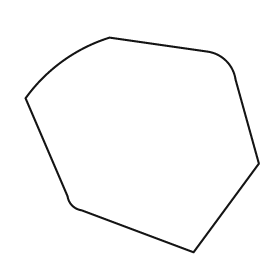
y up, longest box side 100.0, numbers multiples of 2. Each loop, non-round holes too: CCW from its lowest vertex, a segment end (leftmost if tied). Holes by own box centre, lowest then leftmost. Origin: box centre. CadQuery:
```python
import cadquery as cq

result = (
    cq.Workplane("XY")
    .moveTo(22.0, -46.0)
    .lineTo(50.0, -8.0)
    .lineTo(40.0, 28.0)
    .threePointArc((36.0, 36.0), (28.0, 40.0))
    .lineTo(-14.0, 46.0)
    .threePointArc((-34.0, 36.0), (-50.0, 20.0))
    .lineTo(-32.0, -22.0)
    .threePointArc((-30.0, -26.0), (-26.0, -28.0))
    .close()
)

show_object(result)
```